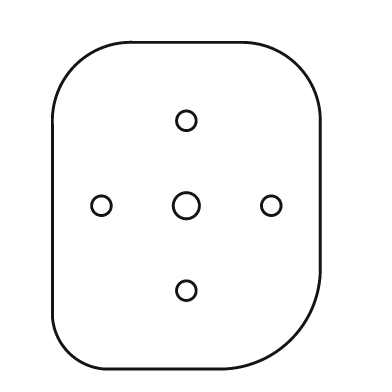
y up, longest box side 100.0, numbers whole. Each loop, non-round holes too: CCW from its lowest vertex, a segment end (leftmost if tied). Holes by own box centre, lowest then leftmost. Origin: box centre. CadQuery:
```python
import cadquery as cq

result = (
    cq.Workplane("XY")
    .moveTo(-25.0, -50.0)
    .lineTo(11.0, -50.0)
    .threePointArc((32.0, -41.0), (41.0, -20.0))
    .lineTo(41.0, 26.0)
    .threePointArc((34.0, 43.0), (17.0, 50.0))
    .lineTo(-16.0, 50.0)
    .threePointArc((-34.0, 43.0), (-41.0, 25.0))
    .lineTo(-41.0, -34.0)
    .threePointArc((-36.0, -45.0), (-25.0, -50.0))
    .close()
    .moveTo(0.0, -26.0)
    .circle(3.0)
    .moveTo(-26.0, 0.0)
    .circle(3.0)
    .moveTo(0.0, 0.0)
    .circle(4.0)
    .moveTo(26.0, 0.0)
    .circle(3.0)
    .moveTo(0.0, 26.0)
    .circle(3.0)
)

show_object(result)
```